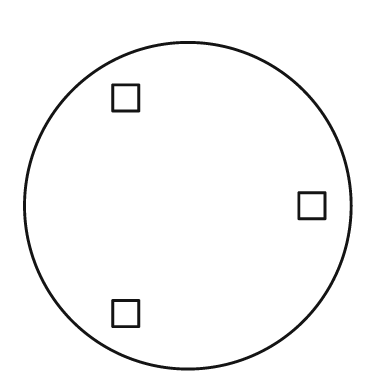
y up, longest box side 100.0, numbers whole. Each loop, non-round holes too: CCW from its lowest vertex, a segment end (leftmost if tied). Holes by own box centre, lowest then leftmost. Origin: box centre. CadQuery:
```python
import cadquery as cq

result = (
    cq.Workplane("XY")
    .moveTo(0.0, 0.0)
    .circle(50.0)
    .moveTo(-23.0, -37.0)
    .lineTo(-15.0, -37.0)
    .lineTo(-15.0, -29.0)
    .lineTo(-23.0, -29.0)
    .close()
    .moveTo(34.0, -4.0)
    .lineTo(42.0, -4.0)
    .lineTo(42.0, 4.0)
    .lineTo(34.0, 4.0)
    .close()
    .moveTo(-23.0, 29.0)
    .lineTo(-15.0, 29.0)
    .lineTo(-15.0, 37.0)
    .lineTo(-23.0, 37.0)
    .close()
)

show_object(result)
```